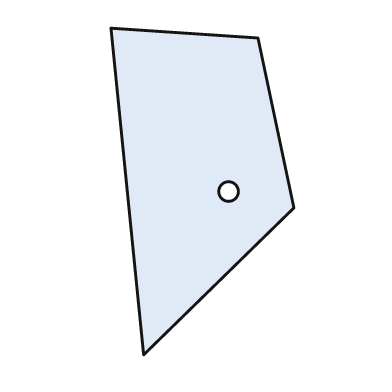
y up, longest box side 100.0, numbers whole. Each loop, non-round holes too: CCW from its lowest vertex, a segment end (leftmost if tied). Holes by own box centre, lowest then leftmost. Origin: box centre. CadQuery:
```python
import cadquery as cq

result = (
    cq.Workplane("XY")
    .moveTo(-18.0, -50.0)
    .lineTo(28.0, -5.0)
    .lineTo(17.0, 47.0)
    .lineTo(-28.0, 50.0)
    .close()
    .moveTo(8.0, 0.0)
    .circle(3.0)
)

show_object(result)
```